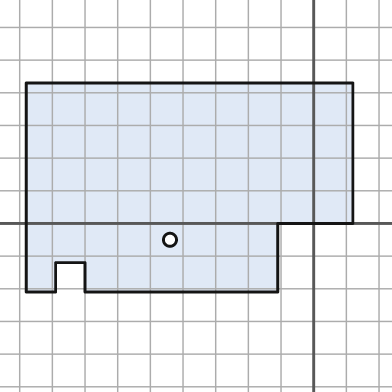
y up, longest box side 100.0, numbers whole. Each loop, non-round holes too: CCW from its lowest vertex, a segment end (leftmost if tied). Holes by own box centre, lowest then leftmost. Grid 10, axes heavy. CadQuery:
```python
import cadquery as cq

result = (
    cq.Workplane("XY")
    .moveTo(-88.0, -21.0)
    .lineTo(-79.0, -21.0)
    .lineTo(-79.0, -12.0)
    .lineTo(-70.0, -12.0)
    .lineTo(-70.0, -21.0)
    .lineTo(-11.0, -21.0)
    .lineTo(-11.0, 0.0)
    .lineTo(12.0, 0.0)
    .lineTo(12.0, 43.0)
    .lineTo(-88.0, 43.0)
    .close()
    .moveTo(-44.0, -5.0)
    .circle(2.0)
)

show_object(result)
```